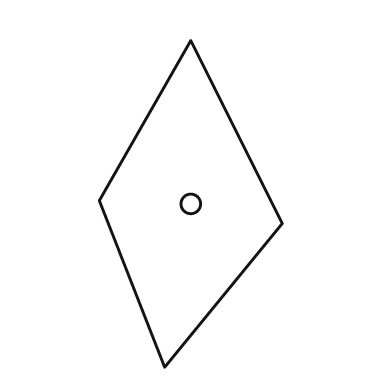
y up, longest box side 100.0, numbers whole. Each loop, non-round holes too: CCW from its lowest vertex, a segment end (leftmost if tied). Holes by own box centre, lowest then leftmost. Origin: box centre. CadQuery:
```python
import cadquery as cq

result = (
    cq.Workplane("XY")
    .moveTo(-8.0, -50.0)
    .lineTo(28.0, -6.0)
    .lineTo(0.0, 50.0)
    .lineTo(-28.0, 1.0)
    .close()
    .moveTo(0.0, 0.0)
    .circle(3.0)
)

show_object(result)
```